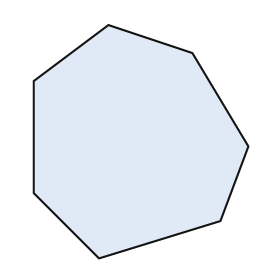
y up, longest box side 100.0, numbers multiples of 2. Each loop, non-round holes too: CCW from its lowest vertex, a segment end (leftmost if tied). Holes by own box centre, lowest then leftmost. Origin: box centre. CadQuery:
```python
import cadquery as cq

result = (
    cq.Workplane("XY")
    .moveTo(-18.0, -50.0)
    .lineTo(34.0, -34.0)
    .lineTo(46.0, -2.0)
    .lineTo(22.0, 38.0)
    .lineTo(-14.0, 50.0)
    .lineTo(-46.0, 26.0)
    .lineTo(-46.0, -22.0)
    .close()
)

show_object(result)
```